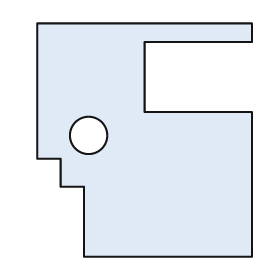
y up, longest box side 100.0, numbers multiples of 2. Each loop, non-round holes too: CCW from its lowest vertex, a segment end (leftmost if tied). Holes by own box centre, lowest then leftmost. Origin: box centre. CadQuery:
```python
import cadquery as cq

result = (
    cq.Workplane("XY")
    .moveTo(-26.0, -50.0)
    .lineTo(46.0, -50.0)
    .lineTo(46.0, 12.0)
    .lineTo(0.0, 12.0)
    .lineTo(0.0, 42.0)
    .lineTo(46.0, 42.0)
    .lineTo(46.0, 50.0)
    .lineTo(-46.0, 50.0)
    .lineTo(-46.0, -8.0)
    .lineTo(-36.0, -8.0)
    .lineTo(-36.0, -20.0)
    .lineTo(-26.0, -20.0)
    .close()
    .moveTo(-24.0, 2.0)
    .circle(8.0)
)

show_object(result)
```